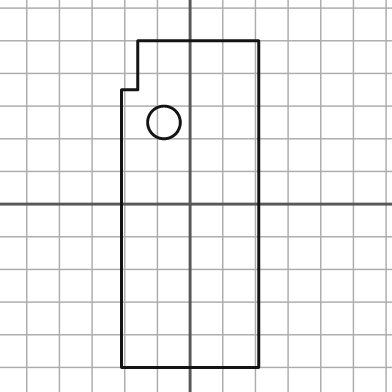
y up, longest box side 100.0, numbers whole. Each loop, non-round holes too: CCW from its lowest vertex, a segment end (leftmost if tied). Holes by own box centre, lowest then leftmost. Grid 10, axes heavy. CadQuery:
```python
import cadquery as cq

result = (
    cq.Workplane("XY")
    .moveTo(-21.0, -50.0)
    .lineTo(21.0, -50.0)
    .lineTo(21.0, 50.0)
    .lineTo(-16.0, 50.0)
    .lineTo(-16.0, 35.0)
    .lineTo(-21.0, 35.0)
    .close()
    .moveTo(-8.0, 25.0)
    .circle(5.0)
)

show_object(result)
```